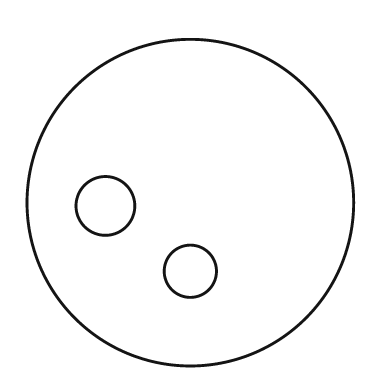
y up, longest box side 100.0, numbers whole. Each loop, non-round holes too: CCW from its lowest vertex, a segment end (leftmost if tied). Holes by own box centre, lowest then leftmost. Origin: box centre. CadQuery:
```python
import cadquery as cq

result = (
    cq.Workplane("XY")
    .moveTo(0.0, 0.0)
    .circle(50.0)
    .moveTo(0.0, -21.0)
    .circle(8.0)
    .moveTo(-26.0, -1.0)
    .circle(9.0)
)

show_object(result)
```